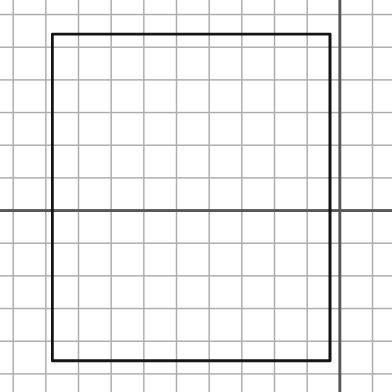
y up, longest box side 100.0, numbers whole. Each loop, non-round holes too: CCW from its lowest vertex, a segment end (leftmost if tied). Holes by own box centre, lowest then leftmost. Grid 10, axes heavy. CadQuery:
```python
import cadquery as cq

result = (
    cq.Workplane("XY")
    .moveTo(-88.0, -46.0)
    .lineTo(-3.0, -46.0)
    .lineTo(-3.0, 54.0)
    .lineTo(-88.0, 54.0)
    .close()
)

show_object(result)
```